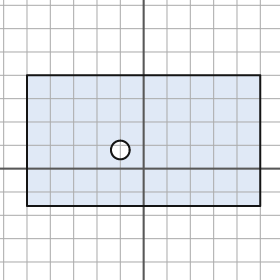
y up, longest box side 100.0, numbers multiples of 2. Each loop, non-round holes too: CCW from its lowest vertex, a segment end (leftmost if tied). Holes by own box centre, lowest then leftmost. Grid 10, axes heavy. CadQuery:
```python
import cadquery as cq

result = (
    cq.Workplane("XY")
    .moveTo(-50.0, -16.0)
    .lineTo(50.0, -16.0)
    .lineTo(50.0, 40.0)
    .lineTo(-50.0, 40.0)
    .close()
    .moveTo(-10.0, 8.0)
    .circle(4.0)
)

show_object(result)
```